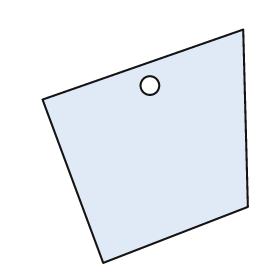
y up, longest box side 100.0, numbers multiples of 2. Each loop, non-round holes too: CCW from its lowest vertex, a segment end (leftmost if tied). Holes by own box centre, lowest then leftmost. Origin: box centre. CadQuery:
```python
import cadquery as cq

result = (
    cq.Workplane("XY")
    .moveTo(-18.0, -50.0)
    .lineTo(44.0, -26.0)
    .lineTo(42.0, 50.0)
    .lineTo(-44.0, 20.0)
    .close()
    .moveTo(2.0, 26.0)
    .circle(4.0)
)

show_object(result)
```